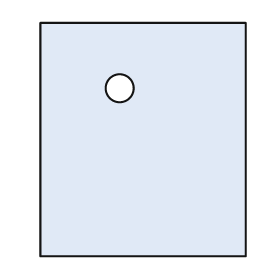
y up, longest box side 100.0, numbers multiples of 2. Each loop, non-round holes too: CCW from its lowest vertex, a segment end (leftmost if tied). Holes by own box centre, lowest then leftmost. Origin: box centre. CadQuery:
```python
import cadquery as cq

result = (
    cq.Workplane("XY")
    .moveTo(-44.0, -50.0)
    .lineTo(44.0, -50.0)
    .lineTo(44.0, 50.0)
    .lineTo(-44.0, 50.0)
    .close()
    .moveTo(-10.0, 22.0)
    .circle(6.0)
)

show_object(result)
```